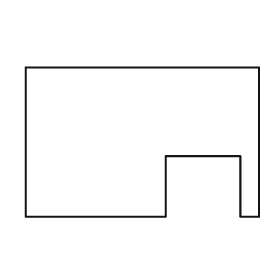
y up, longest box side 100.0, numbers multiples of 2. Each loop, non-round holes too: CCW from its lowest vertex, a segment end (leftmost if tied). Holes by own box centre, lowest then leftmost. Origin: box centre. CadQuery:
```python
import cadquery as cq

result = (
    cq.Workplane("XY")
    .moveTo(-50.0, -32.0)
    .lineTo(10.0, -32.0)
    .lineTo(10.0, -6.0)
    .lineTo(42.0, -6.0)
    .lineTo(42.0, -32.0)
    .lineTo(50.0, -32.0)
    .lineTo(50.0, 32.0)
    .lineTo(-50.0, 32.0)
    .close()
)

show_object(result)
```